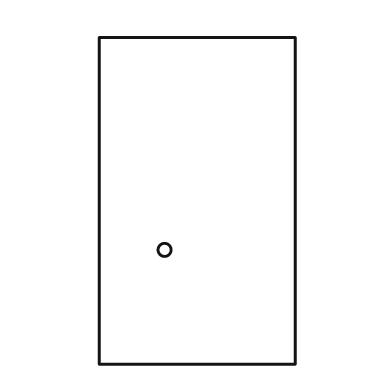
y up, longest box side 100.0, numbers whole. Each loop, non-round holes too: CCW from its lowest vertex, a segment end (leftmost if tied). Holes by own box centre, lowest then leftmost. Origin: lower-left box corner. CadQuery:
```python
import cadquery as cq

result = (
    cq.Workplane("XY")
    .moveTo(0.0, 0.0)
    .lineTo(60.0, 0.0)
    .lineTo(60.0, 100.0)
    .lineTo(0.0, 100.0)
    .close()
    .moveTo(20.0, 35.0)
    .circle(2.0)
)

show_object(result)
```